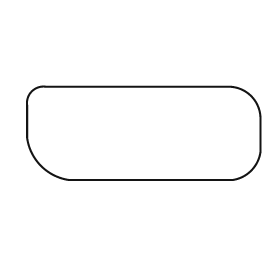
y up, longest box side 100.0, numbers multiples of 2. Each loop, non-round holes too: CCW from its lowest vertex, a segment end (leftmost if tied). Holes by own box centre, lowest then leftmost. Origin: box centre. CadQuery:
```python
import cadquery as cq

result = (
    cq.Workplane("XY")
    .moveTo(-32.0, -20.0)
    .lineTo(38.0, -20.0)
    .threePointArc((46.0, -16.0), (50.0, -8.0))
    .lineTo(50.0, 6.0)
    .threePointArc((46.0, 16.0), (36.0, 20.0))
    .lineTo(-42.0, 20.0)
    .threePointArc((-48.0, 18.0), (-50.0, 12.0))
    .lineTo(-50.0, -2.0)
    .threePointArc((-44.0, -14.0), (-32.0, -20.0))
    .close()
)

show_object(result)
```